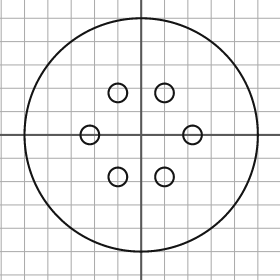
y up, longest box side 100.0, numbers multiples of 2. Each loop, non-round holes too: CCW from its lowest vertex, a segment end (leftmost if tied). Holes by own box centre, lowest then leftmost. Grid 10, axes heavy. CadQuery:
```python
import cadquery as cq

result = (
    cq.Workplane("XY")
    .moveTo(0.0, 0.0)
    .circle(50.0)
    .moveTo(-10.0, -18.0)
    .circle(4.0)
    .moveTo(10.0, -18.0)
    .circle(4.0)
    .moveTo(-22.0, 0.0)
    .circle(4.0)
    .moveTo(22.0, 0.0)
    .circle(4.0)
    .moveTo(-10.0, 18.0)
    .circle(4.0)
    .moveTo(10.0, 18.0)
    .circle(4.0)
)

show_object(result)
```